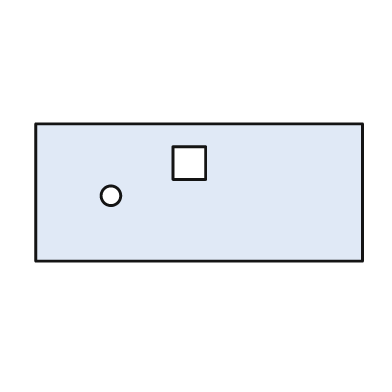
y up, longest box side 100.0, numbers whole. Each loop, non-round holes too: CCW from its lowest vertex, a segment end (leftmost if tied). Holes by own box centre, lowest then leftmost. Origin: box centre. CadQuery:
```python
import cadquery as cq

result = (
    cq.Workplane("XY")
    .moveTo(-50.0, -21.0)
    .lineTo(50.0, -21.0)
    .lineTo(50.0, 21.0)
    .lineTo(-50.0, 21.0)
    .close()
    .moveTo(-27.0, -1.0)
    .circle(3.0)
    .moveTo(-8.0, 4.0)
    .lineTo(2.0, 4.0)
    .lineTo(2.0, 14.0)
    .lineTo(-8.0, 14.0)
    .close()
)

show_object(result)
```